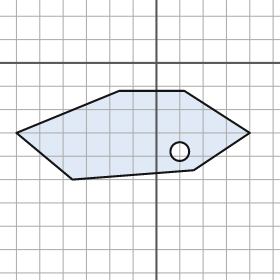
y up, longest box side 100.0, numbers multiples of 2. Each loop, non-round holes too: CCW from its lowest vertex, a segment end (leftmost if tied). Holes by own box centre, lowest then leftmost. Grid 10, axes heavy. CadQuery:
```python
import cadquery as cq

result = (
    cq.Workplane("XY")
    .moveTo(-36.0, -50.0)
    .lineTo(16.0, -46.0)
    .lineTo(40.0, -30.0)
    .lineTo(12.0, -12.0)
    .lineTo(-16.0, -12.0)
    .lineTo(-60.0, -30.0)
    .close()
    .moveTo(10.0, -38.0)
    .circle(4.0)
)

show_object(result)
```